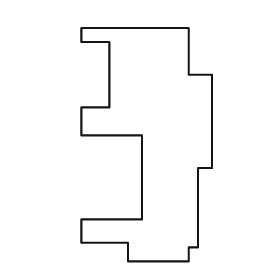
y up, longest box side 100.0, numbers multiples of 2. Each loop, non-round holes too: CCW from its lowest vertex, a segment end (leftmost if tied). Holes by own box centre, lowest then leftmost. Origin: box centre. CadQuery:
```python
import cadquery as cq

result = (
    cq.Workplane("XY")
    .moveTo(-8.0, -50.0)
    .lineTo(18.0, -50.0)
    .lineTo(18.0, -44.0)
    .lineTo(22.0, -44.0)
    .lineTo(22.0, -10.0)
    .lineTo(28.0, -10.0)
    .lineTo(28.0, 30.0)
    .lineTo(18.0, 30.0)
    .lineTo(18.0, 50.0)
    .lineTo(-28.0, 50.0)
    .lineTo(-28.0, 44.0)
    .lineTo(-16.0, 44.0)
    .lineTo(-16.0, 16.0)
    .lineTo(-28.0, 16.0)
    .lineTo(-28.0, 4.0)
    .lineTo(-2.0, 4.0)
    .lineTo(-2.0, -32.0)
    .lineTo(-28.0, -32.0)
    .lineTo(-28.0, -42.0)
    .lineTo(-8.0, -42.0)
    .close()
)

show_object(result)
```